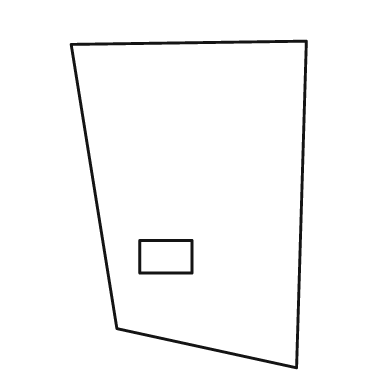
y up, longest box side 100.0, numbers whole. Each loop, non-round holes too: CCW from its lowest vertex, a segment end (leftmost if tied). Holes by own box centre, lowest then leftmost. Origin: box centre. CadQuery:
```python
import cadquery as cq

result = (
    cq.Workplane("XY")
    .moveTo(33.0, -50.0)
    .lineTo(36.0, 50.0)
    .lineTo(-36.0, 49.0)
    .lineTo(-22.0, -38.0)
    .close()
    .moveTo(-15.0, -21.0)
    .lineTo(1.0, -21.0)
    .lineTo(1.0, -11.0)
    .lineTo(-15.0, -11.0)
    .close()
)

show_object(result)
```